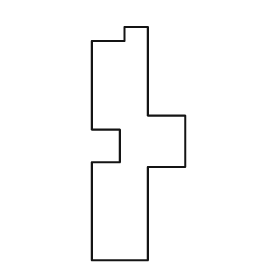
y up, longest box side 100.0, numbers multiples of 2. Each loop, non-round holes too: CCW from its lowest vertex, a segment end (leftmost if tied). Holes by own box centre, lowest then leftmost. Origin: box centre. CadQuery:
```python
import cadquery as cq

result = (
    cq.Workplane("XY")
    .moveTo(-20.0, -50.0)
    .lineTo(4.0, -50.0)
    .lineTo(4.0, -10.0)
    .lineTo(20.0, -10.0)
    .lineTo(20.0, 12.0)
    .lineTo(4.0, 12.0)
    .lineTo(4.0, 50.0)
    .lineTo(-6.0, 50.0)
    .lineTo(-6.0, 44.0)
    .lineTo(-20.0, 44.0)
    .lineTo(-20.0, 6.0)
    .lineTo(-8.0, 6.0)
    .lineTo(-8.0, -8.0)
    .lineTo(-20.0, -8.0)
    .close()
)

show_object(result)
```